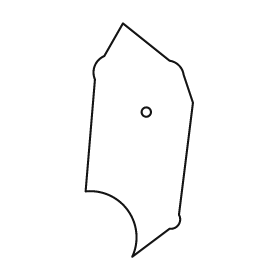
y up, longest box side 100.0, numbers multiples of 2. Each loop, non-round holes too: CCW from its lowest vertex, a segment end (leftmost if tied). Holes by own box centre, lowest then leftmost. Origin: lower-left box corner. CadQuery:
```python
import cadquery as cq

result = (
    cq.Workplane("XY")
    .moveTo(20.0, 0.0)
    .lineTo(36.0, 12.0)
    .threePointArc((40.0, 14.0), (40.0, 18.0))
    .lineTo(46.0, 66.0)
    .lineTo(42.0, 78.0)
    .threePointArc((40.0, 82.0), (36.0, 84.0))
    .lineTo(16.0, 100.0)
    .lineTo(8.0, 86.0)
    .threePointArc((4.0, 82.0), (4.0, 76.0))
    .lineTo(0.0, 28.0)
    .threePointArc((18.0, 20.0), (20.0, 0.0))
    .close()
    .moveTo(26.0, 62.0)
    .circle(2.0)
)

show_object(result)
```